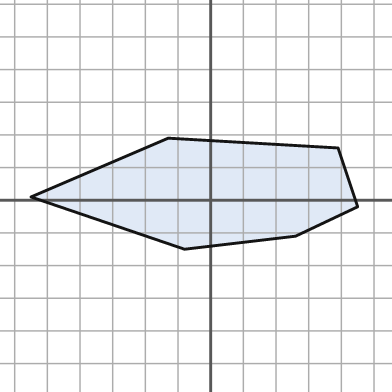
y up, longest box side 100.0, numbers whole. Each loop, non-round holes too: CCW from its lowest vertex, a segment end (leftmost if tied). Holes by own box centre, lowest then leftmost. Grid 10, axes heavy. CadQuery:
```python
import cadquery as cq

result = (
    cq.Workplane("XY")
    .moveTo(-8.0, -15.0)
    .lineTo(26.0, -11.0)
    .lineTo(45.0, -2.0)
    .lineTo(39.0, 16.0)
    .lineTo(-13.0, 19.0)
    .lineTo(-55.0, 1.0)
    .close()
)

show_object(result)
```